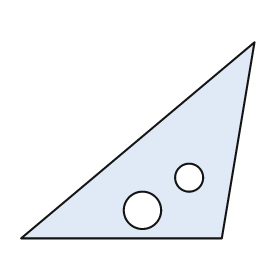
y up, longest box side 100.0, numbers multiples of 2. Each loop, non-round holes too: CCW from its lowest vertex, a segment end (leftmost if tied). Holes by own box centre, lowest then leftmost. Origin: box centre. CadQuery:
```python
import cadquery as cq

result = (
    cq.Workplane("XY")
    .moveTo(-50.0, -42.0)
    .lineTo(36.0, -42.0)
    .lineTo(50.0, 42.0)
    .close()
    .moveTo(2.0, -30.0)
    .circle(8.0)
    .moveTo(22.0, -16.0)
    .circle(6.0)
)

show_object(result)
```